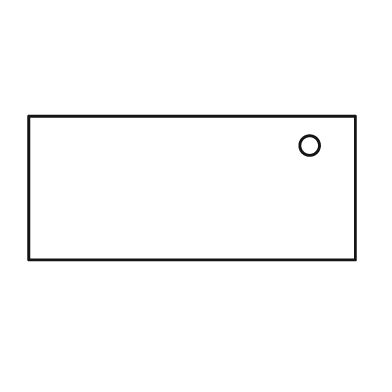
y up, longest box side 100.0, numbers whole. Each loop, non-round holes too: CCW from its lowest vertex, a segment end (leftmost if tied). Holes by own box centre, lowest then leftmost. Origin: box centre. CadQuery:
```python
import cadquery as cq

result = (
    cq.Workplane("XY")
    .moveTo(-50.0, -22.0)
    .lineTo(50.0, -22.0)
    .lineTo(50.0, 22.0)
    .lineTo(-50.0, 22.0)
    .close()
    .moveTo(36.0, 13.0)
    .circle(3.0)
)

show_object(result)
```